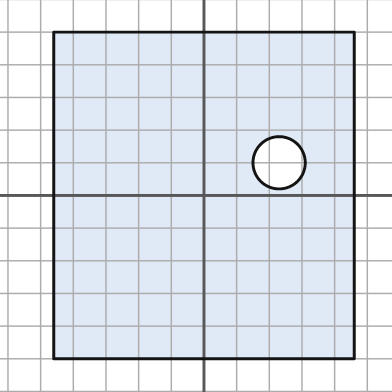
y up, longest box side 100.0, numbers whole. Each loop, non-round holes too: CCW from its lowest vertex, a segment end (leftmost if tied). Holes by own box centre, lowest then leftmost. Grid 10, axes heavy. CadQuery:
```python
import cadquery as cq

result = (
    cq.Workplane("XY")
    .moveTo(-46.0, -50.0)
    .lineTo(46.0, -50.0)
    .lineTo(46.0, 50.0)
    .lineTo(-46.0, 50.0)
    .close()
    .moveTo(23.0, 10.0)
    .circle(8.0)
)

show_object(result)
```